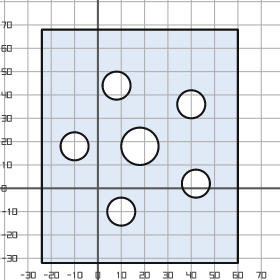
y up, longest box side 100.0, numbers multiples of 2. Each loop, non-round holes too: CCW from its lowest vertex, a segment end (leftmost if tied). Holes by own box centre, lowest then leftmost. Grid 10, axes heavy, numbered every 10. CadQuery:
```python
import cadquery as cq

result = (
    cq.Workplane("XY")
    .moveTo(-24.0, -32.0)
    .lineTo(60.0, -32.0)
    .lineTo(60.0, 68.0)
    .lineTo(-24.0, 68.0)
    .close()
    .moveTo(10.0, -10.0)
    .circle(6.0)
    .moveTo(42.0, 2.0)
    .circle(6.0)
    .moveTo(-10.0, 18.0)
    .circle(6.0)
    .moveTo(18.0, 18.0)
    .circle(8.0)
    .moveTo(40.0, 36.0)
    .circle(6.0)
    .moveTo(8.0, 44.0)
    .circle(6.0)
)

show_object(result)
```